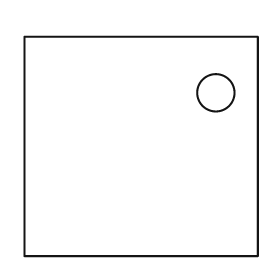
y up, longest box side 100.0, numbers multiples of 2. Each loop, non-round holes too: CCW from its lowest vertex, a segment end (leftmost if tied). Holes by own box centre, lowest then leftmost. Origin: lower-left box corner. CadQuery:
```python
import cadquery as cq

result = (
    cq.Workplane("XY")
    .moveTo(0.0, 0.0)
    .lineTo(100.0, 0.0)
    .lineTo(100.0, 94.0)
    .lineTo(0.0, 94.0)
    .close()
    .moveTo(82.0, 70.0)
    .circle(8.0)
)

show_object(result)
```